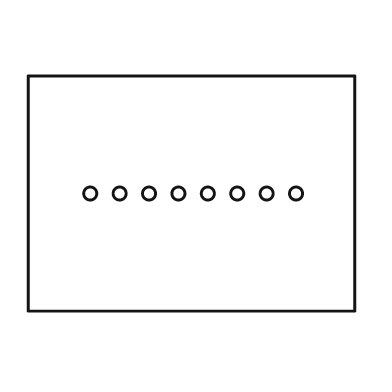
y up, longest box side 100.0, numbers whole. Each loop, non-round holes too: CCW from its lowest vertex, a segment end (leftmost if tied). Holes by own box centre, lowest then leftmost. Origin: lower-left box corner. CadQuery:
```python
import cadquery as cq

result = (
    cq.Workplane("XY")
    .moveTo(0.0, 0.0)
    .lineTo(100.0, 0.0)
    .lineTo(100.0, 72.0)
    .lineTo(0.0, 72.0)
    .close()
    .moveTo(19.0, 36.0)
    .circle(2.0)
    .moveTo(28.0, 36.0)
    .circle(2.0)
    .moveTo(37.0, 36.0)
    .circle(2.0)
    .moveTo(46.0, 36.0)
    .circle(2.0)
    .moveTo(55.0, 36.0)
    .circle(2.0)
    .moveTo(64.0, 36.0)
    .circle(2.0)
    .moveTo(73.0, 36.0)
    .circle(2.0)
    .moveTo(82.0, 36.0)
    .circle(2.0)
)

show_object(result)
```